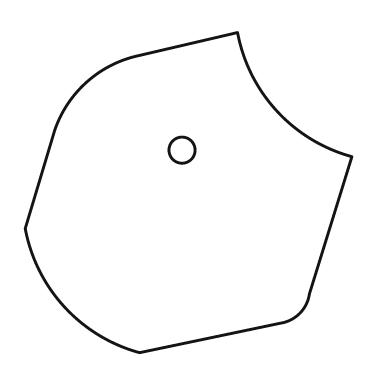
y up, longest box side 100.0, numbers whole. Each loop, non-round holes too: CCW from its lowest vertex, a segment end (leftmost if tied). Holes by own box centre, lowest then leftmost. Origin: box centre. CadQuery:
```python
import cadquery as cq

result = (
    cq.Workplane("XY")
    .moveTo(-15.0, -49.0)
    .lineTo(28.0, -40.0)
    .threePointArc((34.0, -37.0), (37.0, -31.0))
    .lineTo(50.0, 11.0)
    .threePointArc((27.0, 25.0), (15.0, 49.0))
    .lineTo(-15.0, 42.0)
    .threePointArc((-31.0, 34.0), (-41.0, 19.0))
    .lineTo(-50.0, -11.0)
    .threePointArc((-38.0, -35.0), (-15.0, -49.0))
    .close()
    .moveTo(-2.0, 13.0)
    .circle(4.0)
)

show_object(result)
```